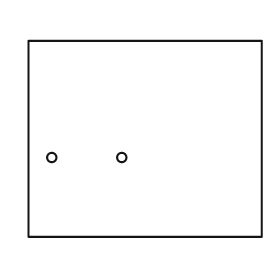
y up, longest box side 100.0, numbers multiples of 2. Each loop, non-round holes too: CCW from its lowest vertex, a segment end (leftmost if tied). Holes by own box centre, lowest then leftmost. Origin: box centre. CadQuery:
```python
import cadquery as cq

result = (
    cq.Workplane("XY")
    .moveTo(-50.0, -42.0)
    .lineTo(50.0, -42.0)
    .lineTo(50.0, 42.0)
    .lineTo(-50.0, 42.0)
    .close()
    .moveTo(-40.0, -8.0)
    .circle(2.0)
    .moveTo(-10.0, -8.0)
    .circle(2.0)
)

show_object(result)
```